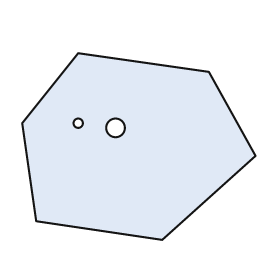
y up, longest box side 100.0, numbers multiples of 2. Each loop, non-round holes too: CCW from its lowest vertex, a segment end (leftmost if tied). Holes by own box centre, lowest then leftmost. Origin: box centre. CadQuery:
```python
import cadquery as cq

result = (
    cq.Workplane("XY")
    .moveTo(10.0, -40.0)
    .lineTo(50.0, -4.0)
    .lineTo(30.0, 32.0)
    .lineTo(-26.0, 40.0)
    .lineTo(-50.0, 10.0)
    .lineTo(-44.0, -32.0)
    .close()
    .moveTo(-10.0, 8.0)
    .circle(4.0)
    .moveTo(-26.0, 10.0)
    .circle(2.0)
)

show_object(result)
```